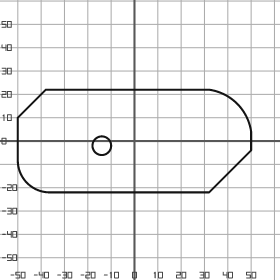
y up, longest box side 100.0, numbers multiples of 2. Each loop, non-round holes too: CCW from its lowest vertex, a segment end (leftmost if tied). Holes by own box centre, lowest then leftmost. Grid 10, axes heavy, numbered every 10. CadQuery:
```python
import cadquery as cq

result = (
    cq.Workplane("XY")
    .moveTo(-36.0, -22.0)
    .lineTo(32.0, -22.0)
    .lineTo(50.0, -4.0)
    .lineTo(50.0, 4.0)
    .threePointArc((44.0, 16.0), (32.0, 22.0))
    .lineTo(-38.0, 22.0)
    .lineTo(-50.0, 10.0)
    .lineTo(-50.0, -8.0)
    .threePointArc((-46.0, -18.0), (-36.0, -22.0))
    .close()
    .moveTo(-14.0, -2.0)
    .circle(4.0)
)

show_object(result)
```